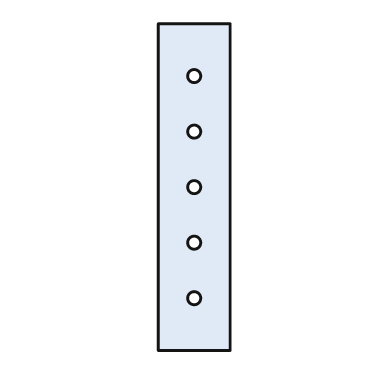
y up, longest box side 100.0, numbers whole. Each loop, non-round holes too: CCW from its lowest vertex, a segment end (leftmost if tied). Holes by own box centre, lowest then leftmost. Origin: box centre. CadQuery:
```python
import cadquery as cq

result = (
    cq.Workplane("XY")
    .moveTo(-11.0, -50.0)
    .lineTo(11.0, -50.0)
    .lineTo(11.0, 50.0)
    .lineTo(-11.0, 50.0)
    .close()
    .moveTo(0.0, -34.0)
    .circle(2.0)
    .moveTo(0.0, -17.0)
    .circle(2.0)
    .moveTo(0.0, 0.0)
    .circle(2.0)
    .moveTo(0.0, 17.0)
    .circle(2.0)
    .moveTo(0.0, 34.0)
    .circle(2.0)
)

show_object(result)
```